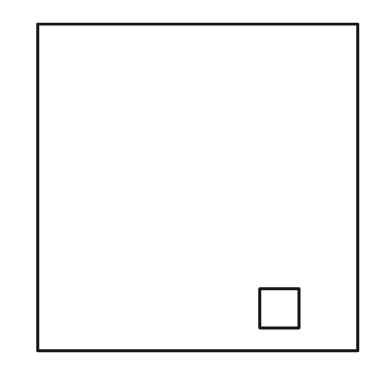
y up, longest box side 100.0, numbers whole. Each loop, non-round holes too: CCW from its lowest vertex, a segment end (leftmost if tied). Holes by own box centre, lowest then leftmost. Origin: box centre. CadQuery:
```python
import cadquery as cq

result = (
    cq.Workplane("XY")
    .moveTo(-49.0, -50.0)
    .lineTo(49.0, -50.0)
    .lineTo(49.0, 50.0)
    .lineTo(-49.0, 50.0)
    .close()
    .moveTo(19.0, -43.0)
    .lineTo(31.0, -43.0)
    .lineTo(31.0, -31.0)
    .lineTo(19.0, -31.0)
    .close()
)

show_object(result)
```